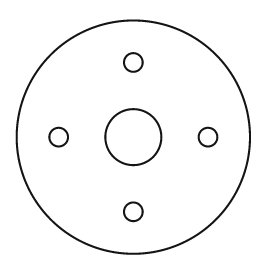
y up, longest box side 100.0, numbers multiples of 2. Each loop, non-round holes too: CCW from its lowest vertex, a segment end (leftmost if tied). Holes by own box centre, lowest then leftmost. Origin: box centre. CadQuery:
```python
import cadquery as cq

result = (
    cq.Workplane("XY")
    .moveTo(0.0, 0.0)
    .circle(50.0)
    .moveTo(0.0, -32.0)
    .circle(4.0)
    .moveTo(-32.0, 0.0)
    .circle(4.0)
    .moveTo(0.0, 0.0)
    .circle(12.0)
    .moveTo(32.0, 0.0)
    .circle(4.0)
    .moveTo(0.0, 32.0)
    .circle(4.0)
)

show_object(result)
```